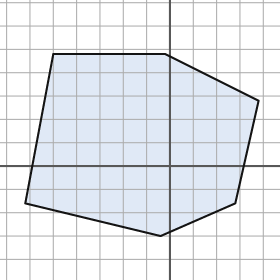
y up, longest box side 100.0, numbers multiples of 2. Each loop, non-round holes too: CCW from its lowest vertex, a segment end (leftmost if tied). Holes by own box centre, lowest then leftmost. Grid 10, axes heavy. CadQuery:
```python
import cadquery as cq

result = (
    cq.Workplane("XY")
    .moveTo(-4.0, -30.0)
    .lineTo(28.0, -16.0)
    .lineTo(38.0, 28.0)
    .lineTo(-2.0, 48.0)
    .lineTo(-50.0, 48.0)
    .lineTo(-62.0, -16.0)
    .close()
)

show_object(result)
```